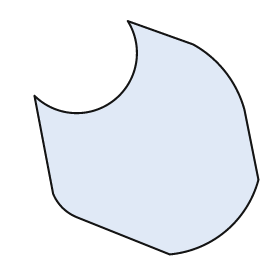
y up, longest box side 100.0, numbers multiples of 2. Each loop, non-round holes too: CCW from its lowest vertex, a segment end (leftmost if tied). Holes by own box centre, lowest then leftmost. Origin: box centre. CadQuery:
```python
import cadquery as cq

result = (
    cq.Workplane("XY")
    .moveTo(10.0, -50.0)
    .threePointArc((34.0, -40.0), (48.0, -18.0))
    .lineTo(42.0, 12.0)
    .threePointArc((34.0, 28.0), (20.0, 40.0))
    .lineTo(-8.0, 50.0)
    .threePointArc((-14.0, 16.0), (-48.0, 18.0))
    .lineTo(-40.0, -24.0)
    .threePointArc((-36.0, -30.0), (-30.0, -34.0))
    .close()
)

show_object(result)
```